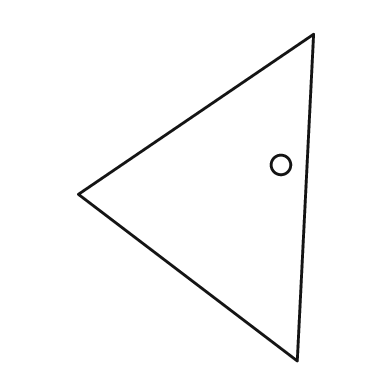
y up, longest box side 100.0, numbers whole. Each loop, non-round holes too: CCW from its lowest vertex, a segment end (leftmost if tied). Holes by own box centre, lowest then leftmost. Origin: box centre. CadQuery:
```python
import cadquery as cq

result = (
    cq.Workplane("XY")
    .moveTo(31.0, -50.0)
    .lineTo(36.0, 50.0)
    .lineTo(-36.0, 1.0)
    .close()
    .moveTo(26.0, 10.0)
    .circle(3.0)
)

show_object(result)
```